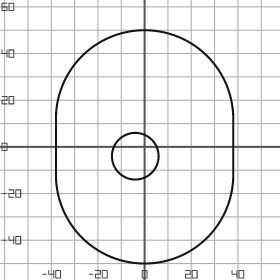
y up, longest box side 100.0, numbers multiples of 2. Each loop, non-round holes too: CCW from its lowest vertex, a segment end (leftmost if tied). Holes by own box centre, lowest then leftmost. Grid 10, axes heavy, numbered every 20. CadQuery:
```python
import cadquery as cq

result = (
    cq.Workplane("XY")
    .moveTo(-38.0, -12.0)
    .threePointArc((0.0, -50.0), (38.0, -12.0))
    .lineTo(38.0, 12.0)
    .threePointArc((0.0, 50.0), (-38.0, 12.0))
    .close()
    .moveTo(-4.0, -4.0)
    .circle(10.0)
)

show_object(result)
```